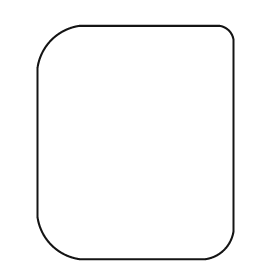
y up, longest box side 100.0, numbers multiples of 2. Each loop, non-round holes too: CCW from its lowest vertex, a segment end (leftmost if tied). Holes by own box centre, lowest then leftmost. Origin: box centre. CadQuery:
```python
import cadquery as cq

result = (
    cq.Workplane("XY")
    .moveTo(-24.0, -50.0)
    .lineTo(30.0, -50.0)
    .threePointArc((38.0, -46.0), (42.0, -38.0))
    .lineTo(42.0, 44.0)
    .threePointArc((40.0, 48.0), (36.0, 50.0))
    .lineTo(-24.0, 50.0)
    .threePointArc((-36.0, 44.0), (-42.0, 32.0))
    .lineTo(-42.0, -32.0)
    .threePointArc((-36.0, -44.0), (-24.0, -50.0))
    .close()
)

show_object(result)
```